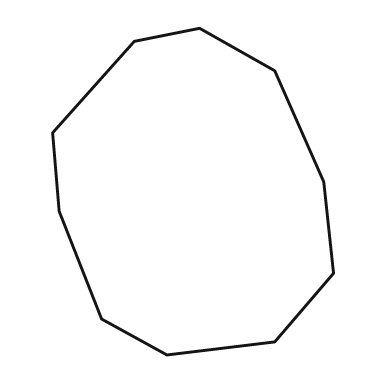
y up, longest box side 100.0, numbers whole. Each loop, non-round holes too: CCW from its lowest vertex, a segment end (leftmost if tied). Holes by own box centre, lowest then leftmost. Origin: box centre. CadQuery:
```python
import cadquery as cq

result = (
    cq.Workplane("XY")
    .moveTo(-8.0, -50.0)
    .lineTo(25.0, -46.0)
    .lineTo(43.0, -25.0)
    .lineTo(40.0, 3.0)
    .lineTo(25.0, 37.0)
    .lineTo(2.0, 50.0)
    .lineTo(-18.0, 46.0)
    .lineTo(-43.0, 18.0)
    .lineTo(-41.0, -6.0)
    .lineTo(-28.0, -39.0)
    .close()
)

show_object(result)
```